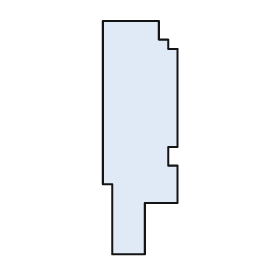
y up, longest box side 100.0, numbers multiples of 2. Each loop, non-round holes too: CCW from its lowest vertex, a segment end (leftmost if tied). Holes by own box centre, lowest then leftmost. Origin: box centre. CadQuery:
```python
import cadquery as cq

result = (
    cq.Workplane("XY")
    .moveTo(-12.0, -50.0)
    .lineTo(2.0, -50.0)
    .lineTo(2.0, -28.0)
    .lineTo(16.0, -28.0)
    .lineTo(16.0, -12.0)
    .lineTo(12.0, -12.0)
    .lineTo(12.0, -4.0)
    .lineTo(16.0, -4.0)
    .lineTo(16.0, 38.0)
    .lineTo(12.0, 38.0)
    .lineTo(12.0, 42.0)
    .lineTo(8.0, 42.0)
    .lineTo(8.0, 50.0)
    .lineTo(-16.0, 50.0)
    .lineTo(-16.0, -20.0)
    .lineTo(-12.0, -20.0)
    .close()
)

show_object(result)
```